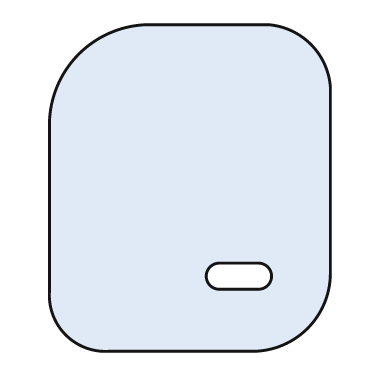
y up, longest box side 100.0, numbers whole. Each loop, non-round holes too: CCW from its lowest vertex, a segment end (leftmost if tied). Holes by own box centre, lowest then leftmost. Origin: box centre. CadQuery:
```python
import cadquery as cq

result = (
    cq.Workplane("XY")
    .moveTo(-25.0, -50.0)
    .lineTo(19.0, -50.0)
    .threePointArc((36.0, -43.0), (43.0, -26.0))
    .lineTo(43.0, 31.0)
    .threePointArc((37.0, 44.0), (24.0, 50.0))
    .lineTo(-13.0, 50.0)
    .threePointArc((-34.0, 41.0), (-43.0, 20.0))
    .lineTo(-43.0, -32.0)
    .threePointArc((-38.0, -45.0), (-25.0, -50.0))
    .close()
    .moveTo(9.0, -31.0)
    .lineTo(21.0, -31.0)
    .threePointArc((25.0, -27.0), (21.0, -23.0))
    .lineTo(9.0, -23.0)
    .threePointArc((5.0, -27.0), (9.0, -31.0))
    .close()
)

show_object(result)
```